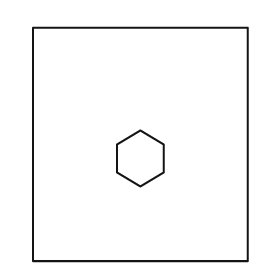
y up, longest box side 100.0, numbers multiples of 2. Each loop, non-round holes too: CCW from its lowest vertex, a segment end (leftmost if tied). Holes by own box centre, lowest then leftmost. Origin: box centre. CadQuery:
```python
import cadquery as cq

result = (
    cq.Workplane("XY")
    .moveTo(-46.0, -50.0)
    .lineTo(46.0, -50.0)
    .lineTo(46.0, 50.0)
    .lineTo(-46.0, 50.0)
    .close()
    .moveTo(0.0, -18.0)
    .lineTo(10.0, -12.0)
    .lineTo(10.0, 0.0)
    .lineTo(0.0, 6.0)
    .lineTo(-10.0, 0.0)
    .lineTo(-10.0, -12.0)
    .close()
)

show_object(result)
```